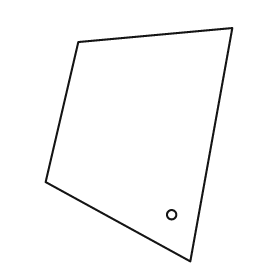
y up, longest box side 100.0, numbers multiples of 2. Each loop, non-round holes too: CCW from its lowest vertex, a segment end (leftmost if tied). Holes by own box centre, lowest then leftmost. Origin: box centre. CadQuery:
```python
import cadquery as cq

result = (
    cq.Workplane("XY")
    .moveTo(22.0, -50.0)
    .lineTo(40.0, 50.0)
    .lineTo(-26.0, 44.0)
    .lineTo(-40.0, -16.0)
    .close()
    .moveTo(14.0, -30.0)
    .circle(2.0)
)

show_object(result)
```